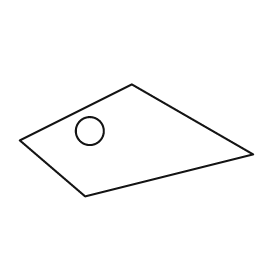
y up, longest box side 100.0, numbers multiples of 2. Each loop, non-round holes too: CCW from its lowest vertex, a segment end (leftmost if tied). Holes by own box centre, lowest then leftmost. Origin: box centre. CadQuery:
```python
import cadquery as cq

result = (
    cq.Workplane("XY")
    .moveTo(-22.0, -24.0)
    .lineTo(50.0, -6.0)
    .lineTo(-2.0, 24.0)
    .lineTo(-50.0, 0.0)
    .close()
    .moveTo(-20.0, 4.0)
    .circle(6.0)
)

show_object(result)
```